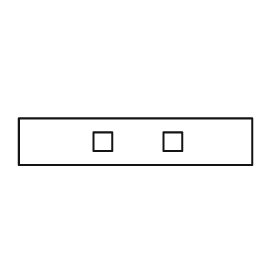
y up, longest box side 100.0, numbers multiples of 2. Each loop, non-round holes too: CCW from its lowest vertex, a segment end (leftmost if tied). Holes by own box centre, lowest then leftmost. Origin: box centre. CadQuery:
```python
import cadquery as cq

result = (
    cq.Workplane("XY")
    .moveTo(-50.0, -10.0)
    .lineTo(50.0, -10.0)
    .lineTo(50.0, 10.0)
    .lineTo(-50.0, 10.0)
    .close()
    .moveTo(-18.0, -4.0)
    .lineTo(-10.0, -4.0)
    .lineTo(-10.0, 4.0)
    .lineTo(-18.0, 4.0)
    .close()
    .moveTo(12.0, -4.0)
    .lineTo(20.0, -4.0)
    .lineTo(20.0, 4.0)
    .lineTo(12.0, 4.0)
    .close()
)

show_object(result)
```